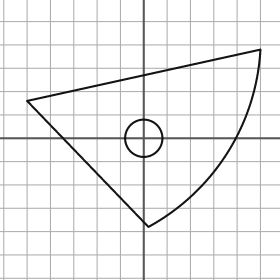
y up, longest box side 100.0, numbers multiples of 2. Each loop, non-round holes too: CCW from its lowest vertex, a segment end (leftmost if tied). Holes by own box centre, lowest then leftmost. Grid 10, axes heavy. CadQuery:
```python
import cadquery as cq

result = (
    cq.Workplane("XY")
    .moveTo(2.0, -38.0)
    .threePointArc((36.0, -6.0), (50.0, 38.0))
    .lineTo(-50.0, 16.0)
    .close()
    .moveTo(0.0, 0.0)
    .circle(8.0)
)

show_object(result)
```